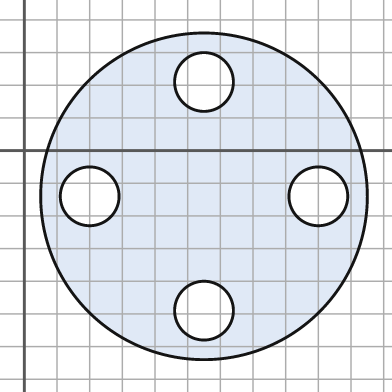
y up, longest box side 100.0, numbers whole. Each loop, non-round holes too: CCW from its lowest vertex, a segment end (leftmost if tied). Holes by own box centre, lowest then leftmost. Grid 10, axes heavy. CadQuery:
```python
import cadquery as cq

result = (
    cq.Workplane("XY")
    .moveTo(55.0, -14.0)
    .circle(50.0)
    .moveTo(55.0, -49.0)
    .circle(9.0)
    .moveTo(20.0, -14.0)
    .circle(9.0)
    .moveTo(90.0, -14.0)
    .circle(9.0)
    .moveTo(55.0, 21.0)
    .circle(9.0)
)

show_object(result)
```